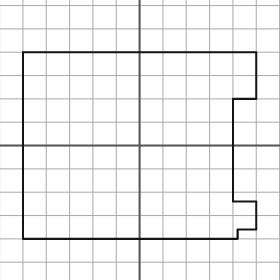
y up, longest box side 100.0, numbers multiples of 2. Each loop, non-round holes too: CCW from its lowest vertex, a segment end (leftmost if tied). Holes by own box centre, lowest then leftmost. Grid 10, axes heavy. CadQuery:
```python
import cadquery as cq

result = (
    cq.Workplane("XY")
    .moveTo(-50.0, -40.0)
    .lineTo(42.0, -40.0)
    .lineTo(42.0, -36.0)
    .lineTo(50.0, -36.0)
    .lineTo(50.0, -24.0)
    .lineTo(40.0, -24.0)
    .lineTo(40.0, 20.0)
    .lineTo(50.0, 20.0)
    .lineTo(50.0, 40.0)
    .lineTo(-50.0, 40.0)
    .close()
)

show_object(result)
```